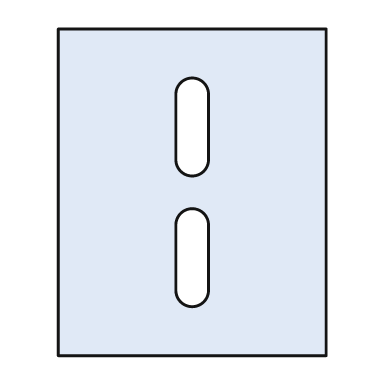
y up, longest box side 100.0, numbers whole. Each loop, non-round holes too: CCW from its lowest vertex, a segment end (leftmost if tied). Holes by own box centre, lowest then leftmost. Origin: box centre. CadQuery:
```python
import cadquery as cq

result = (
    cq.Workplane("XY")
    .moveTo(-41.0, -50.0)
    .lineTo(41.0, -50.0)
    .lineTo(41.0, 50.0)
    .lineTo(-41.0, 50.0)
    .close()
    .moveTo(-5.0, -30.0)
    .threePointArc((0.0, -35.0), (5.0, -30.0))
    .lineTo(5.0, -10.0)
    .threePointArc((0.0, -5.0), (-5.0, -10.0))
    .close()
    .moveTo(-5.0, 10.0)
    .threePointArc((0.0, 5.0), (5.0, 10.0))
    .lineTo(5.0, 30.0)
    .threePointArc((0.0, 35.0), (-5.0, 30.0))
    .close()
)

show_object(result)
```